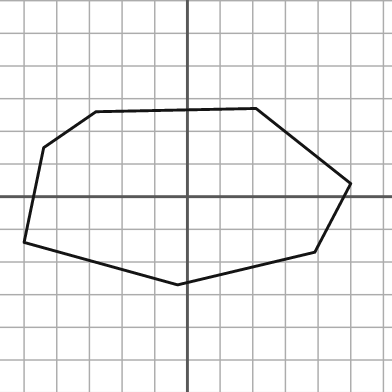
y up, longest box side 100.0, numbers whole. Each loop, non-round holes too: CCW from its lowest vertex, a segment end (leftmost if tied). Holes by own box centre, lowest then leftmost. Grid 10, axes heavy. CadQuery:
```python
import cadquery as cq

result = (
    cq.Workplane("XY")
    .moveTo(-3.0, -27.0)
    .lineTo(39.0, -17.0)
    .lineTo(50.0, 4.0)
    .lineTo(21.0, 27.0)
    .lineTo(-28.0, 26.0)
    .lineTo(-44.0, 15.0)
    .lineTo(-50.0, -14.0)
    .close()
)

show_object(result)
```